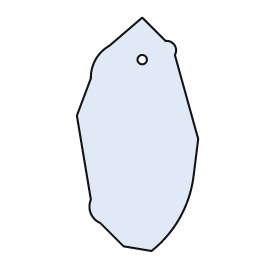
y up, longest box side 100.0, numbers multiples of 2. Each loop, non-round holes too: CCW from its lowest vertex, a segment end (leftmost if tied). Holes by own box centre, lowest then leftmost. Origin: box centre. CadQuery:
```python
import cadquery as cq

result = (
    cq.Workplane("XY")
    .moveTo(6.0, -50.0)
    .threePointArc((18.0, -36.0), (24.0, -18.0))
    .lineTo(26.0, -2.0)
    .lineTo(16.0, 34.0)
    .threePointArc((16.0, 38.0), (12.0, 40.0))
    .lineTo(2.0, 50.0)
    .lineTo(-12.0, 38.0)
    .threePointArc((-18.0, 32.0), (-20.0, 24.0))
    .lineTo(-26.0, 8.0)
    .lineTo(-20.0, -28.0)
    .threePointArc((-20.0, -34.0), (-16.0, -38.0))
    .lineTo(-6.0, -48.0)
    .close()
    .moveTo(2.0, 32.0)
    .circle(2.0)
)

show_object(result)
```